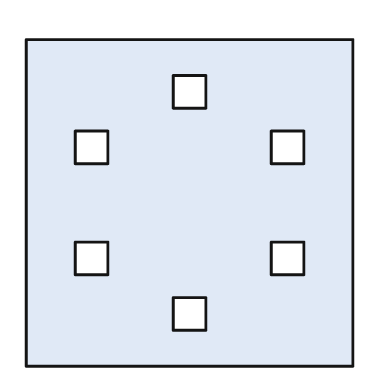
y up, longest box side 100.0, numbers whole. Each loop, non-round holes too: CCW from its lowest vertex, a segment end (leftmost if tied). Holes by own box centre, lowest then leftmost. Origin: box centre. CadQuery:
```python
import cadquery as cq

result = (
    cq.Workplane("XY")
    .moveTo(-50.0, -50.0)
    .lineTo(50.0, -50.0)
    .lineTo(50.0, 50.0)
    .lineTo(-50.0, 50.0)
    .close()
    .moveTo(-5.0, -39.0)
    .lineTo(5.0, -39.0)
    .lineTo(5.0, -29.0)
    .lineTo(-5.0, -29.0)
    .close()
    .moveTo(-35.0, -22.0)
    .lineTo(-25.0, -22.0)
    .lineTo(-25.0, -12.0)
    .lineTo(-35.0, -12.0)
    .close()
    .moveTo(25.0, -22.0)
    .lineTo(35.0, -22.0)
    .lineTo(35.0, -12.0)
    .lineTo(25.0, -12.0)
    .close()
    .moveTo(-35.0, 12.0)
    .lineTo(-25.0, 12.0)
    .lineTo(-25.0, 22.0)
    .lineTo(-35.0, 22.0)
    .close()
    .moveTo(25.0, 12.0)
    .lineTo(35.0, 12.0)
    .lineTo(35.0, 22.0)
    .lineTo(25.0, 22.0)
    .close()
    .moveTo(-5.0, 29.0)
    .lineTo(5.0, 29.0)
    .lineTo(5.0, 39.0)
    .lineTo(-5.0, 39.0)
    .close()
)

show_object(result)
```